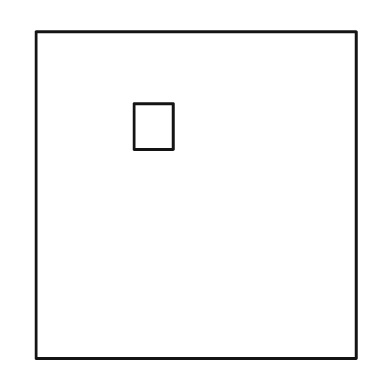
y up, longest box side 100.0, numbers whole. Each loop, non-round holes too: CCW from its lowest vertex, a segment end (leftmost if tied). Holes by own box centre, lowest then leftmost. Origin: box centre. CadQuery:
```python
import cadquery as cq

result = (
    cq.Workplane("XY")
    .moveTo(-49.0, -50.0)
    .lineTo(49.0, -50.0)
    .lineTo(49.0, 50.0)
    .lineTo(-49.0, 50.0)
    .close()
    .moveTo(-19.0, 14.0)
    .lineTo(-7.0, 14.0)
    .lineTo(-7.0, 28.0)
    .lineTo(-19.0, 28.0)
    .close()
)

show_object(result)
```